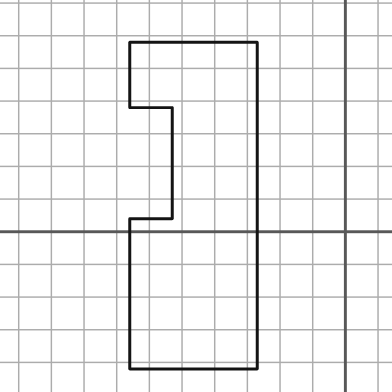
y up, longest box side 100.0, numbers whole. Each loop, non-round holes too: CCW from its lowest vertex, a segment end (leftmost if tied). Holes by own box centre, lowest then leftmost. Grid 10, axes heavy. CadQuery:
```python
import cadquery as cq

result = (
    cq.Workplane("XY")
    .moveTo(-66.0, -42.0)
    .lineTo(-27.0, -42.0)
    .lineTo(-27.0, 58.0)
    .lineTo(-66.0, 58.0)
    .lineTo(-66.0, 38.0)
    .lineTo(-53.0, 38.0)
    .lineTo(-53.0, 4.0)
    .lineTo(-66.0, 4.0)
    .close()
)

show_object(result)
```